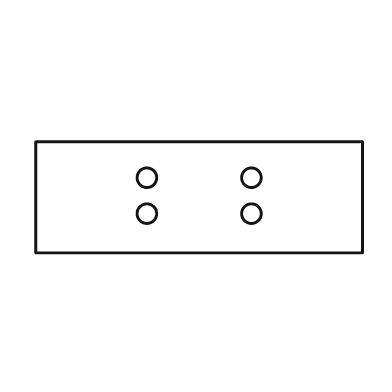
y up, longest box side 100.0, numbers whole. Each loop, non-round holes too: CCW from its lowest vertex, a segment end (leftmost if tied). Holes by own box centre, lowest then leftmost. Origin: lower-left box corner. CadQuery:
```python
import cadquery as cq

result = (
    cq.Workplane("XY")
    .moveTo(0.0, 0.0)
    .lineTo(100.0, 0.0)
    .lineTo(100.0, 34.0)
    .lineTo(0.0, 34.0)
    .close()
    .moveTo(34.0, 12.0)
    .circle(3.0)
    .moveTo(66.0, 12.0)
    .circle(3.0)
    .moveTo(34.0, 23.0)
    .circle(3.0)
    .moveTo(66.0, 23.0)
    .circle(3.0)
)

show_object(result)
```